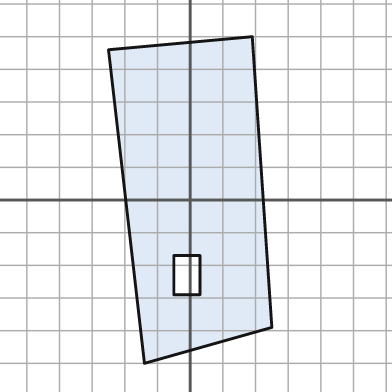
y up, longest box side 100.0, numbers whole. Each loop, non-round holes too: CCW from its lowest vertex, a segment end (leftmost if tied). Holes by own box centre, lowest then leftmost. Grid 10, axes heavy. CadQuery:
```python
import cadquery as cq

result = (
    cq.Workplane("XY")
    .moveTo(-14.0, -50.0)
    .lineTo(25.0, -39.0)
    .lineTo(19.0, 50.0)
    .lineTo(-25.0, 46.0)
    .close()
    .moveTo(-5.0, -29.0)
    .lineTo(3.0, -29.0)
    .lineTo(3.0, -17.0)
    .lineTo(-5.0, -17.0)
    .close()
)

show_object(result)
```